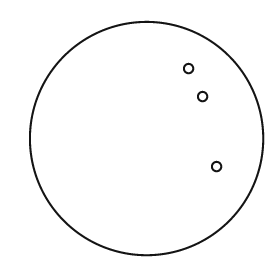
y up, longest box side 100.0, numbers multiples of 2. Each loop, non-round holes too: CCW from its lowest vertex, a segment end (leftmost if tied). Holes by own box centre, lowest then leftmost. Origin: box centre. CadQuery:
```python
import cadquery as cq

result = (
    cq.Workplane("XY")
    .moveTo(0.0, 0.0)
    .circle(50.0)
    .moveTo(30.0, -12.0)
    .circle(2.0)
    .moveTo(24.0, 18.0)
    .circle(2.0)
    .moveTo(18.0, 30.0)
    .circle(2.0)
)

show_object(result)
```